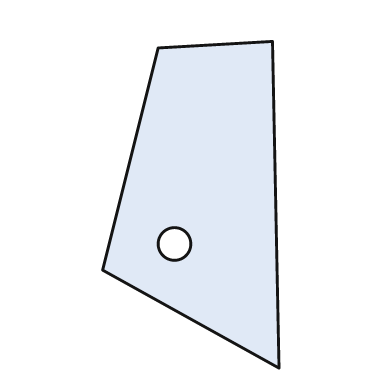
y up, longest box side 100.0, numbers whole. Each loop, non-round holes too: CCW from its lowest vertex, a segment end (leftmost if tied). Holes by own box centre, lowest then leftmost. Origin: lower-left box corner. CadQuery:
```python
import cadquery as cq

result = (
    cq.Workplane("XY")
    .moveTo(54.0, 0.0)
    .lineTo(52.0, 100.0)
    .lineTo(17.0, 98.0)
    .lineTo(0.0, 30.0)
    .close()
    .moveTo(22.0, 38.0)
    .circle(5.0)
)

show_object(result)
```